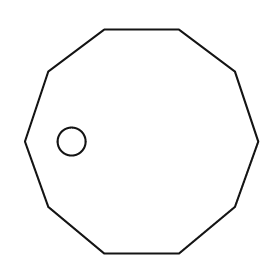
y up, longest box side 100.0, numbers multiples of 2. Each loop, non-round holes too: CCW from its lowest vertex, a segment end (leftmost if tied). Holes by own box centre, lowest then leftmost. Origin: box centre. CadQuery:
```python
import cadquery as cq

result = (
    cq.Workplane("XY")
    .moveTo(-16.0, -48.0)
    .lineTo(16.0, -48.0)
    .lineTo(40.0, -28.0)
    .lineTo(50.0, 0.0)
    .lineTo(40.0, 30.0)
    .lineTo(16.0, 48.0)
    .lineTo(-16.0, 48.0)
    .lineTo(-40.0, 30.0)
    .lineTo(-50.0, 0.0)
    .lineTo(-40.0, -28.0)
    .close()
    .moveTo(-30.0, 0.0)
    .circle(6.0)
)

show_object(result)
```